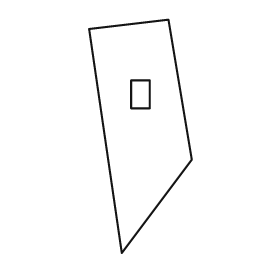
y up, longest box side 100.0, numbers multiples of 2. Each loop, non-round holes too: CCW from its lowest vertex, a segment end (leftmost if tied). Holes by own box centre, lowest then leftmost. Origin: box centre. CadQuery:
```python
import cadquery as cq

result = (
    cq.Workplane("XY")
    .moveTo(-8.0, -50.0)
    .lineTo(22.0, -10.0)
    .lineTo(12.0, 50.0)
    .lineTo(-22.0, 46.0)
    .close()
    .moveTo(-4.0, 12.0)
    .lineTo(4.0, 12.0)
    .lineTo(4.0, 24.0)
    .lineTo(-4.0, 24.0)
    .close()
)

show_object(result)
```